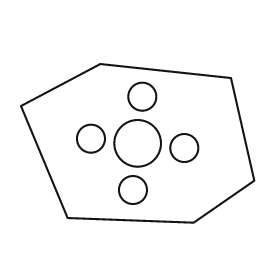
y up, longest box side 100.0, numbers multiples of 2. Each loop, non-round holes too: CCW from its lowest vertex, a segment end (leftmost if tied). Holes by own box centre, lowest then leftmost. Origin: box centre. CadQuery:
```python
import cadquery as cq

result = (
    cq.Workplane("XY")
    .moveTo(24.0, -34.0)
    .lineTo(50.0, -16.0)
    .lineTo(40.0, 28.0)
    .lineTo(-16.0, 34.0)
    .lineTo(-50.0, 16.0)
    .lineTo(-30.0, -32.0)
    .close()
    .moveTo(-2.0, -20.0)
    .circle(6.0)
    .moveTo(20.0, -2.0)
    .circle(6.0)
    .moveTo(0.0, 0.0)
    .circle(10.0)
    .moveTo(-20.0, 2.0)
    .circle(6.0)
    .moveTo(2.0, 20.0)
    .circle(6.0)
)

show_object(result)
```